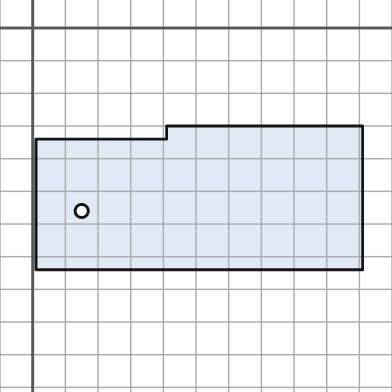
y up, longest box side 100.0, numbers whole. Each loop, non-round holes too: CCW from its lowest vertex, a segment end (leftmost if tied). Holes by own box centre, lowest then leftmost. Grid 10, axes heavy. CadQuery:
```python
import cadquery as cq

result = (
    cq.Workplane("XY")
    .moveTo(1.0, -74.0)
    .lineTo(101.0, -74.0)
    .lineTo(101.0, -30.0)
    .lineTo(41.0, -30.0)
    .lineTo(41.0, -34.0)
    .lineTo(1.0, -34.0)
    .close()
    .moveTo(15.0, -56.0)
    .circle(2.0)
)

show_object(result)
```